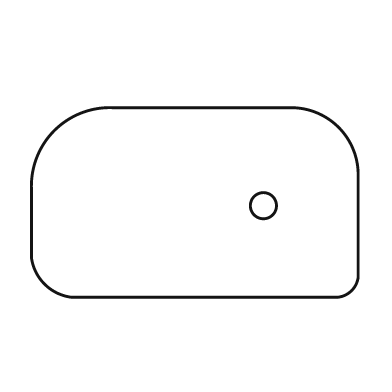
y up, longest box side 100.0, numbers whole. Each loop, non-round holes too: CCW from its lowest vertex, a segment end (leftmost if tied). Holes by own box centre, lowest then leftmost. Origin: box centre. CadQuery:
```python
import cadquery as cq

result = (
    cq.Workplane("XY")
    .moveTo(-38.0, -29.0)
    .lineTo(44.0, -29.0)
    .threePointArc((48.0, -27.0), (50.0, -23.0))
    .lineTo(50.0, 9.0)
    .threePointArc((44.0, 23.0), (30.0, 29.0))
    .lineTo(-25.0, 29.0)
    .threePointArc((-43.0, 22.0), (-50.0, 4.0))
    .lineTo(-50.0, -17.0)
    .threePointArc((-46.0, -25.0), (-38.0, -29.0))
    .close()
    .moveTo(21.0, -1.0)
    .circle(4.0)
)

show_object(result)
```